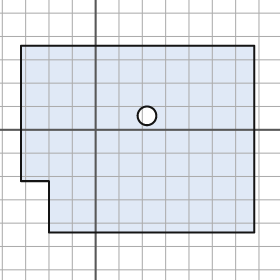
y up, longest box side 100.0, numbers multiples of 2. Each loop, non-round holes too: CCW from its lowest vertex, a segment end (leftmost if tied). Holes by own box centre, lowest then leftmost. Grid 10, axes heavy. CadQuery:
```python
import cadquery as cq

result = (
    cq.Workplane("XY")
    .moveTo(-20.0, -44.0)
    .lineTo(68.0, -44.0)
    .lineTo(68.0, 36.0)
    .lineTo(-32.0, 36.0)
    .lineTo(-32.0, -22.0)
    .lineTo(-20.0, -22.0)
    .close()
    .moveTo(22.0, 6.0)
    .circle(4.0)
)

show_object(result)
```